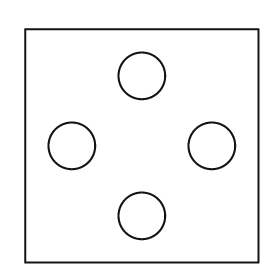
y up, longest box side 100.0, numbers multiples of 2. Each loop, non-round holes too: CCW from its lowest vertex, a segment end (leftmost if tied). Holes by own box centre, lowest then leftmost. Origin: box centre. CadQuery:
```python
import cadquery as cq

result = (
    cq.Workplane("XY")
    .moveTo(-50.0, -50.0)
    .lineTo(50.0, -50.0)
    .lineTo(50.0, 50.0)
    .lineTo(-50.0, 50.0)
    .close()
    .moveTo(0.0, -30.0)
    .circle(10.0)
    .moveTo(-30.0, 0.0)
    .circle(10.0)
    .moveTo(30.0, 0.0)
    .circle(10.0)
    .moveTo(0.0, 30.0)
    .circle(10.0)
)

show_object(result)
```